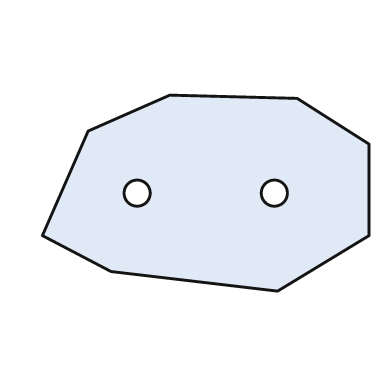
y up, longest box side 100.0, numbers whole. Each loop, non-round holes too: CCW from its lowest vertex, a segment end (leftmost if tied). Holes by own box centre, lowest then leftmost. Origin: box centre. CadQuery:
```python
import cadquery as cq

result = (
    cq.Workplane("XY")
    .moveTo(22.0, -30.0)
    .lineTo(50.0, -13.0)
    .lineTo(50.0, 15.0)
    .lineTo(28.0, 29.0)
    .lineTo(-11.0, 30.0)
    .lineTo(-36.0, 19.0)
    .lineTo(-50.0, -13.0)
    .lineTo(-29.0, -24.0)
    .close()
    .moveTo(-21.0, 0.0)
    .circle(4.0)
    .moveTo(21.0, 0.0)
    .circle(4.0)
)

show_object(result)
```